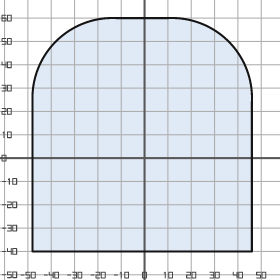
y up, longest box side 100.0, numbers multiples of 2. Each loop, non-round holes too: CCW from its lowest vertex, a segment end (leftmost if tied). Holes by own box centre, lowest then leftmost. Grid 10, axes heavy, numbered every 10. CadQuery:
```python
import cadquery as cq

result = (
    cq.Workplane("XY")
    .moveTo(-48.0, -40.0)
    .lineTo(46.0, -40.0)
    .lineTo(46.0, 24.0)
    .threePointArc((36.0, 50.0), (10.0, 60.0))
    .lineTo(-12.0, 60.0)
    .threePointArc((-38.0, 50.0), (-48.0, 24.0))
    .close()
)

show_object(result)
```